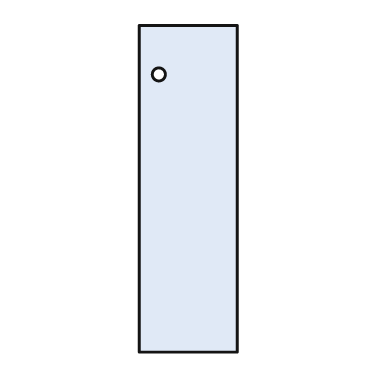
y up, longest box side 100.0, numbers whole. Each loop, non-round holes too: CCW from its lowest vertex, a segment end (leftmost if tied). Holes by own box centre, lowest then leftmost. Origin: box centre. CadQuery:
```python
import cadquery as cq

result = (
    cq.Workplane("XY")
    .moveTo(-15.0, -50.0)
    .lineTo(15.0, -50.0)
    .lineTo(15.0, 50.0)
    .lineTo(-15.0, 50.0)
    .close()
    .moveTo(-9.0, 35.0)
    .circle(2.0)
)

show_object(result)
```